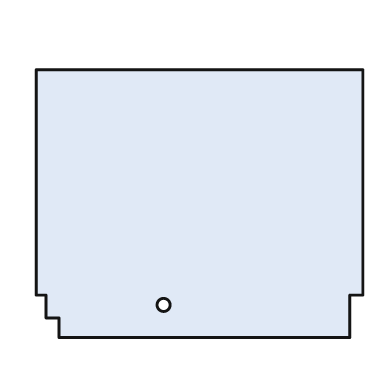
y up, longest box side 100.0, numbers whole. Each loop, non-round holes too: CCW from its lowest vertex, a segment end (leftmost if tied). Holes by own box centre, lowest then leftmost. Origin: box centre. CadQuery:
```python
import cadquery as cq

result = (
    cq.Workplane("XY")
    .moveTo(-43.0, -41.0)
    .lineTo(46.0, -41.0)
    .lineTo(46.0, -28.0)
    .lineTo(50.0, -28.0)
    .lineTo(50.0, 41.0)
    .lineTo(-50.0, 41.0)
    .lineTo(-50.0, -28.0)
    .lineTo(-47.0, -28.0)
    .lineTo(-47.0, -35.0)
    .lineTo(-43.0, -35.0)
    .close()
    .moveTo(-11.0, -31.0)
    .circle(2.0)
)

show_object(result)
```